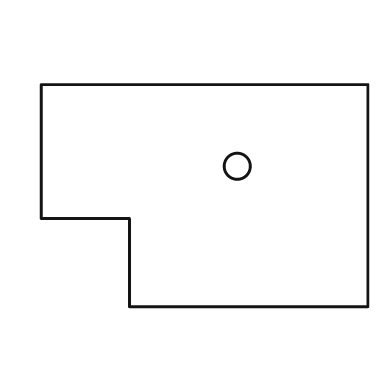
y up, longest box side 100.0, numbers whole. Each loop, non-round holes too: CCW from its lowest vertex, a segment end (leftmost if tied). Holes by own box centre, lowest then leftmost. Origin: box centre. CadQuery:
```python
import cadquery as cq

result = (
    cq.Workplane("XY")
    .moveTo(-23.0, -34.0)
    .lineTo(50.0, -34.0)
    .lineTo(50.0, 34.0)
    .lineTo(-50.0, 34.0)
    .lineTo(-50.0, -7.0)
    .lineTo(-23.0, -7.0)
    .close()
    .moveTo(10.0, 9.0)
    .circle(4.0)
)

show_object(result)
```